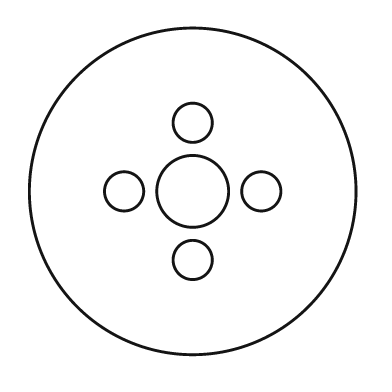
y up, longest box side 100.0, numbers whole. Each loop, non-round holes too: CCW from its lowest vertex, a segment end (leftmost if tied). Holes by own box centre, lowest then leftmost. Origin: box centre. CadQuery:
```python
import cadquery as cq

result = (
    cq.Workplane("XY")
    .moveTo(0.0, 0.0)
    .circle(50.0)
    .moveTo(0.0, -21.0)
    .circle(6.0)
    .moveTo(-21.0, 0.0)
    .circle(6.0)
    .moveTo(0.0, 0.0)
    .circle(11.0)
    .moveTo(21.0, 0.0)
    .circle(6.0)
    .moveTo(0.0, 21.0)
    .circle(6.0)
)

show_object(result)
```